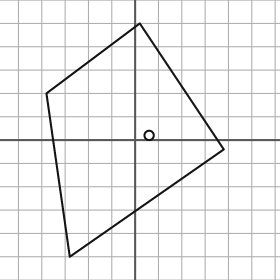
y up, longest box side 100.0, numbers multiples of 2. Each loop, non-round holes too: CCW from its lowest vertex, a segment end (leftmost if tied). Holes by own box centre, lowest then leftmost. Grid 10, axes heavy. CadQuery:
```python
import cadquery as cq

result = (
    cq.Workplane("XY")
    .moveTo(-28.0, -50.0)
    .lineTo(38.0, -4.0)
    .lineTo(2.0, 50.0)
    .lineTo(-38.0, 20.0)
    .close()
    .moveTo(6.0, 2.0)
    .circle(2.0)
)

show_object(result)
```